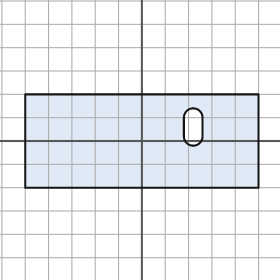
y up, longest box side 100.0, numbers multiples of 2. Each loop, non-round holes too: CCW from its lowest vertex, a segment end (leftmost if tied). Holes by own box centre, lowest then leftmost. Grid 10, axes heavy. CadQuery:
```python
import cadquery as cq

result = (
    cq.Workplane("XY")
    .moveTo(-50.0, -20.0)
    .lineTo(50.0, -20.0)
    .lineTo(50.0, 20.0)
    .lineTo(-50.0, 20.0)
    .close()
    .moveTo(18.0, 2.0)
    .threePointArc((22.0, -2.0), (26.0, 2.0))
    .lineTo(26.0, 10.0)
    .threePointArc((22.0, 14.0), (18.0, 10.0))
    .close()
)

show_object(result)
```